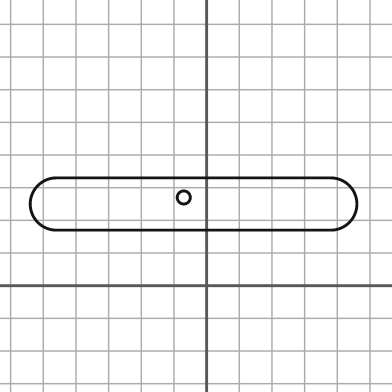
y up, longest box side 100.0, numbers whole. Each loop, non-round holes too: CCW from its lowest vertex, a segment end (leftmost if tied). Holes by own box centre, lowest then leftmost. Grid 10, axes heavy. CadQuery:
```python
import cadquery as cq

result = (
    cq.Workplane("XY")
    .moveTo(-46.0, 17.0)
    .lineTo(38.0, 17.0)
    .threePointArc((46.0, 25.0), (38.0, 33.0))
    .lineTo(-46.0, 33.0)
    .threePointArc((-54.0, 25.0), (-46.0, 17.0))
    .close()
    .moveTo(-7.0, 27.0)
    .circle(2.0)
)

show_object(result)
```